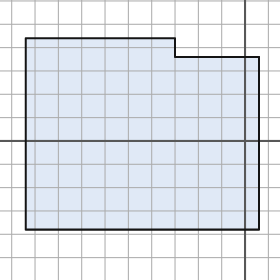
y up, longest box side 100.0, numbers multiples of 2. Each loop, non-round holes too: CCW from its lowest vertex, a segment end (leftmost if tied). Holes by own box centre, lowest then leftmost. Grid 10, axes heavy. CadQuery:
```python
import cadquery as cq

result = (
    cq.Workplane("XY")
    .moveTo(-94.0, -38.0)
    .lineTo(6.0, -38.0)
    .lineTo(6.0, 36.0)
    .lineTo(-30.0, 36.0)
    .lineTo(-30.0, 44.0)
    .lineTo(-94.0, 44.0)
    .close()
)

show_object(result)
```